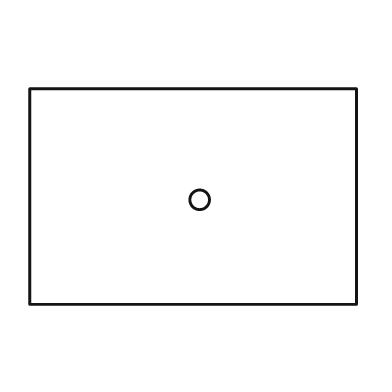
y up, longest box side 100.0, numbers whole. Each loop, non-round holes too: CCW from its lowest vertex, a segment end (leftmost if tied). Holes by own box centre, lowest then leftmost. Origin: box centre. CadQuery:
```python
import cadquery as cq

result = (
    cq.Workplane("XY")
    .moveTo(-50.0, -33.0)
    .lineTo(50.0, -33.0)
    .lineTo(50.0, 33.0)
    .lineTo(-50.0, 33.0)
    .close()
    .moveTo(2.0, -1.0)
    .circle(3.0)
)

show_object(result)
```